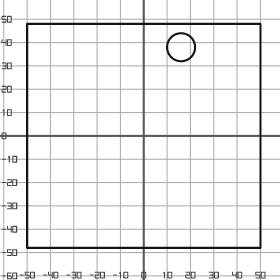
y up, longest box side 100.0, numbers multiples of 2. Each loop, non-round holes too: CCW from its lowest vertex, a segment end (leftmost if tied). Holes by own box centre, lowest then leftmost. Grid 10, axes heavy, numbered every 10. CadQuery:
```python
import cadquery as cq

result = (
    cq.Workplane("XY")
    .moveTo(-50.0, -48.0)
    .lineTo(50.0, -48.0)
    .lineTo(50.0, 48.0)
    .lineTo(-50.0, 48.0)
    .close()
    .moveTo(16.0, 38.0)
    .circle(6.0)
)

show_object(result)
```